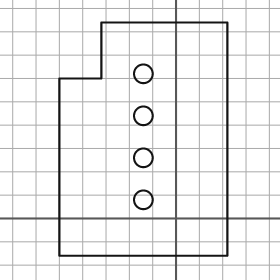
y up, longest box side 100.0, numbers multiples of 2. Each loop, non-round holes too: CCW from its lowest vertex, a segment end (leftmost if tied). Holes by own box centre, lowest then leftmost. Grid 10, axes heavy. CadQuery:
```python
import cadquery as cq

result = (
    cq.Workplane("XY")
    .moveTo(-50.0, -16.0)
    .lineTo(22.0, -16.0)
    .lineTo(22.0, 84.0)
    .lineTo(-32.0, 84.0)
    .lineTo(-32.0, 60.0)
    .lineTo(-50.0, 60.0)
    .close()
    .moveTo(-14.0, 8.0)
    .circle(4.0)
    .moveTo(-14.0, 26.0)
    .circle(4.0)
    .moveTo(-14.0, 44.0)
    .circle(4.0)
    .moveTo(-14.0, 62.0)
    .circle(4.0)
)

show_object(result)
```